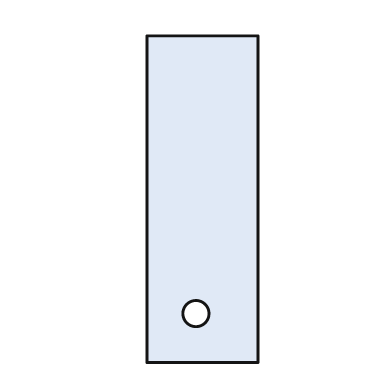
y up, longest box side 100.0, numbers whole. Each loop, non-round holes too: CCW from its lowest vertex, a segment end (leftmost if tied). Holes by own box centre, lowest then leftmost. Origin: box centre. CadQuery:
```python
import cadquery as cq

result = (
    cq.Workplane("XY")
    .moveTo(-17.0, -50.0)
    .lineTo(17.0, -50.0)
    .lineTo(17.0, 50.0)
    .lineTo(-17.0, 50.0)
    .close()
    .moveTo(-2.0, -35.0)
    .circle(4.0)
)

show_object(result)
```